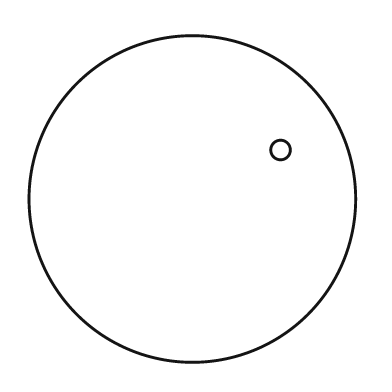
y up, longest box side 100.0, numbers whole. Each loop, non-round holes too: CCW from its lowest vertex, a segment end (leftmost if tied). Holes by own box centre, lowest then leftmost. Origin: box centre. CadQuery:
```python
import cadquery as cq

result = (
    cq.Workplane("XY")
    .moveTo(0.0, 0.0)
    .circle(50.0)
    .moveTo(27.0, 15.0)
    .circle(3.0)
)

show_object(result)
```